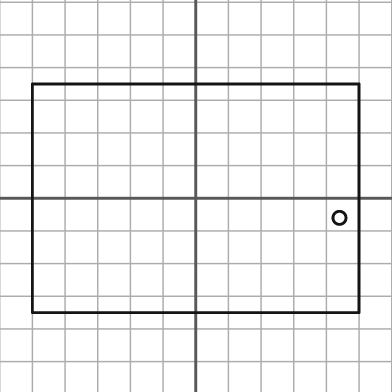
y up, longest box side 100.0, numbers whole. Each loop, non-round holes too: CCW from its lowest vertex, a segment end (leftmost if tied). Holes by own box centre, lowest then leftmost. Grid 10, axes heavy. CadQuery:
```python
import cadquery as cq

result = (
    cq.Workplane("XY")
    .moveTo(-50.0, -35.0)
    .lineTo(50.0, -35.0)
    .lineTo(50.0, 35.0)
    .lineTo(-50.0, 35.0)
    .close()
    .moveTo(44.0, -6.0)
    .circle(2.0)
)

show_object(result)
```